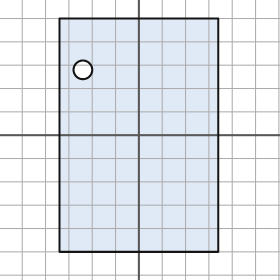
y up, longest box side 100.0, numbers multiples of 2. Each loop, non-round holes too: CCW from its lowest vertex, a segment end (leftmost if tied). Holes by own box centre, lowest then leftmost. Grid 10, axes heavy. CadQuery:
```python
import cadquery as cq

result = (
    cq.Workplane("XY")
    .moveTo(-34.0, -50.0)
    .lineTo(34.0, -50.0)
    .lineTo(34.0, 50.0)
    .lineTo(-34.0, 50.0)
    .close()
    .moveTo(-24.0, 28.0)
    .circle(4.0)
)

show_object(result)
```